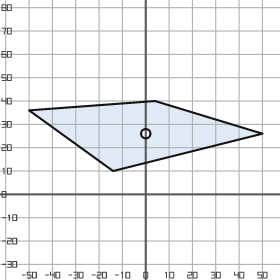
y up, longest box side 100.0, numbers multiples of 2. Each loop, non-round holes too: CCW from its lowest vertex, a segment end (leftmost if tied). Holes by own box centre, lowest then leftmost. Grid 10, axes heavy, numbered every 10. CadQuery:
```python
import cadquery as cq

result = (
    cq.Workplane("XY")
    .moveTo(-14.0, 10.0)
    .lineTo(50.0, 26.0)
    .lineTo(4.0, 40.0)
    .lineTo(-50.0, 36.0)
    .close()
    .moveTo(0.0, 26.0)
    .circle(2.0)
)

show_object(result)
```